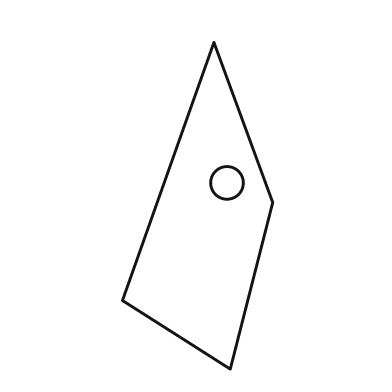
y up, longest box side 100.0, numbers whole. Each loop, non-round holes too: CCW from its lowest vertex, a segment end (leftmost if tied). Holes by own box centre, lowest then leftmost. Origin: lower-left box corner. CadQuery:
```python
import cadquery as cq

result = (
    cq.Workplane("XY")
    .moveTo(33.0, 0.0)
    .lineTo(46.0, 51.0)
    .lineTo(28.0, 100.0)
    .lineTo(0.0, 21.0)
    .close()
    .moveTo(32.0, 57.0)
    .circle(5.0)
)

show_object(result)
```